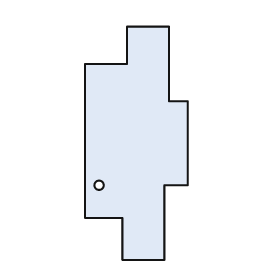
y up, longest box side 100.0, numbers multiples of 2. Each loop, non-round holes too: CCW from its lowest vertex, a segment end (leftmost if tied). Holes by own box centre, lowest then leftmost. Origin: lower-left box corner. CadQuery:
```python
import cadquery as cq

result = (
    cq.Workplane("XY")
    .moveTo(16.0, 0.0)
    .lineTo(34.0, 0.0)
    .lineTo(34.0, 32.0)
    .lineTo(44.0, 32.0)
    .lineTo(44.0, 68.0)
    .lineTo(36.0, 68.0)
    .lineTo(36.0, 100.0)
    .lineTo(18.0, 100.0)
    .lineTo(18.0, 84.0)
    .lineTo(0.0, 84.0)
    .lineTo(0.0, 18.0)
    .lineTo(16.0, 18.0)
    .close()
    .moveTo(6.0, 32.0)
    .circle(2.0)
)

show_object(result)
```